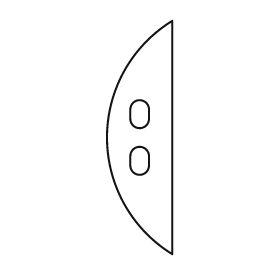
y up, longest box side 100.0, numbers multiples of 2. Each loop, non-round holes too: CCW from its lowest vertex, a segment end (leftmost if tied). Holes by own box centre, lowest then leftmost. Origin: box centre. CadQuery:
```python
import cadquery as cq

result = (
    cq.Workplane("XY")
    .moveTo(14.0, -50.0)
    .lineTo(14.0, 50.0)
    .threePointArc((-14.0, 0.0), (14.0, -50.0))
    .close()
    .moveTo(-4.0, -12.0)
    .threePointArc((0.0, -16.0), (4.0, -12.0))
    .lineTo(4.0, -8.0)
    .threePointArc((0.0, -4.0), (-4.0, -8.0))
    .close()
    .moveTo(-4.0, 8.0)
    .threePointArc((0.0, 4.0), (4.0, 8.0))
    .lineTo(4.0, 12.0)
    .threePointArc((0.0, 16.0), (-4.0, 12.0))
    .close()
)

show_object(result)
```